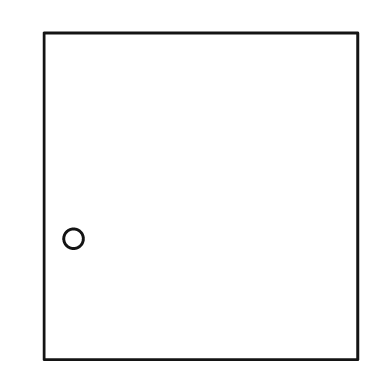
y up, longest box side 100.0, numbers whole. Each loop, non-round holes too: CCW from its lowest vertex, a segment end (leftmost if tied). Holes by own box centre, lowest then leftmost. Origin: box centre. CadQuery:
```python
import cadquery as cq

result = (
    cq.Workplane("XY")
    .moveTo(-48.0, -50.0)
    .lineTo(48.0, -50.0)
    .lineTo(48.0, 50.0)
    .lineTo(-48.0, 50.0)
    .close()
    .moveTo(-39.0, -13.0)
    .circle(3.0)
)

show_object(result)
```